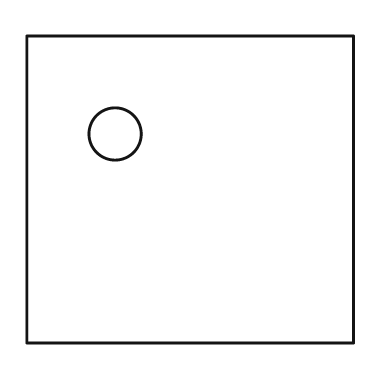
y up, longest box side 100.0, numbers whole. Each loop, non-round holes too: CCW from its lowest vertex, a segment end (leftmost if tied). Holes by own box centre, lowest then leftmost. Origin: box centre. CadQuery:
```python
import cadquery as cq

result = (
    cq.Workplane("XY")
    .moveTo(-50.0, -47.0)
    .lineTo(50.0, -47.0)
    .lineTo(50.0, 47.0)
    .lineTo(-50.0, 47.0)
    .close()
    .moveTo(-23.0, 17.0)
    .circle(8.0)
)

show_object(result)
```